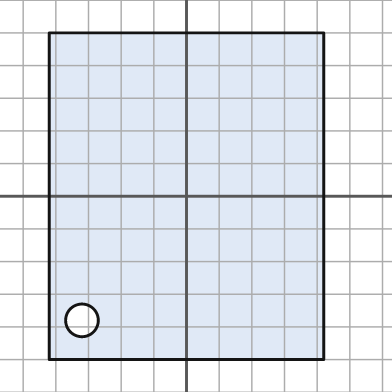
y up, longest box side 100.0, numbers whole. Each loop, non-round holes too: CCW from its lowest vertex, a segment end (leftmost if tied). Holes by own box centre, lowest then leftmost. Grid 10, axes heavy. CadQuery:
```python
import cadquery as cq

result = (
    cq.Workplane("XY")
    .moveTo(-42.0, -50.0)
    .lineTo(42.0, -50.0)
    .lineTo(42.0, 50.0)
    .lineTo(-42.0, 50.0)
    .close()
    .moveTo(-32.0, -38.0)
    .circle(5.0)
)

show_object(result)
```